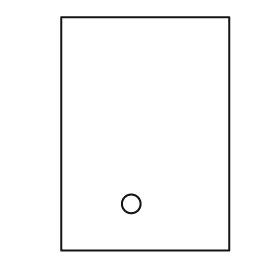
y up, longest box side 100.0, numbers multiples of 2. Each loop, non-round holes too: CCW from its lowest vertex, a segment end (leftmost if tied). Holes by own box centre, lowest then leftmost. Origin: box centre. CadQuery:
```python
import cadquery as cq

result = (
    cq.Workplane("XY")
    .moveTo(-36.0, -50.0)
    .lineTo(36.0, -50.0)
    .lineTo(36.0, 50.0)
    .lineTo(-36.0, 50.0)
    .close()
    .moveTo(-6.0, -30.0)
    .circle(4.0)
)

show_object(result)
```